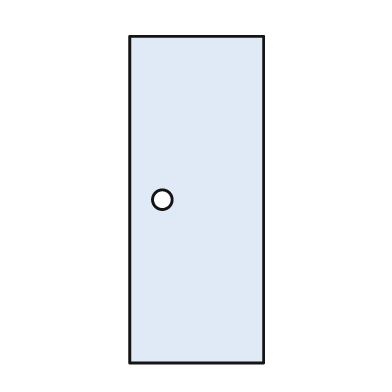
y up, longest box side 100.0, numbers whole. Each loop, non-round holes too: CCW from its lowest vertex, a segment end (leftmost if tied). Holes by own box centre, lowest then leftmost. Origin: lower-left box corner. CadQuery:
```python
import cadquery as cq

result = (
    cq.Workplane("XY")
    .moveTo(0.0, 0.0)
    .lineTo(41.0, 0.0)
    .lineTo(41.0, 100.0)
    .lineTo(0.0, 100.0)
    .close()
    .moveTo(10.0, 50.0)
    .circle(3.0)
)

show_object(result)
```